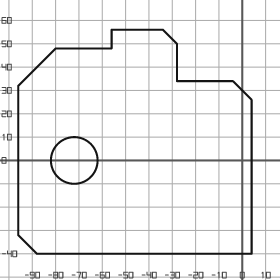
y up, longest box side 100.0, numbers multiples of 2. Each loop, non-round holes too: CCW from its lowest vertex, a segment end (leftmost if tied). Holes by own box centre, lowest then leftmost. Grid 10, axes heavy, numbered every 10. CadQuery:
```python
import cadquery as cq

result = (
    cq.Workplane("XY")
    .moveTo(-88.0, -40.0)
    .lineTo(4.0, -40.0)
    .lineTo(4.0, 26.0)
    .lineTo(-4.0, 34.0)
    .lineTo(-28.0, 34.0)
    .lineTo(-28.0, 50.0)
    .lineTo(-34.0, 56.0)
    .lineTo(-56.0, 56.0)
    .lineTo(-56.0, 48.0)
    .lineTo(-80.0, 48.0)
    .lineTo(-96.0, 32.0)
    .lineTo(-96.0, -32.0)
    .close()
    .moveTo(-72.0, 0.0)
    .circle(10.0)
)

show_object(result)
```